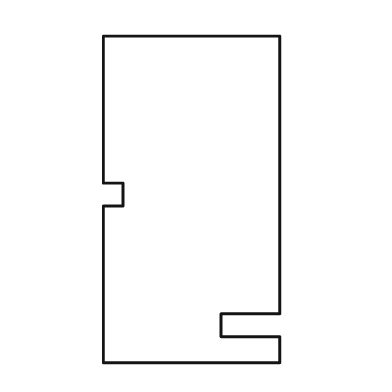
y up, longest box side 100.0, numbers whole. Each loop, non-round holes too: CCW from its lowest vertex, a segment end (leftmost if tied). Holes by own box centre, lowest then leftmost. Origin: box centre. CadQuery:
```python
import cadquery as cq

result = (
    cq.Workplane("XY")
    .moveTo(-27.0, -50.0)
    .lineTo(27.0, -50.0)
    .lineTo(27.0, -42.0)
    .lineTo(9.0, -42.0)
    .lineTo(9.0, -35.0)
    .lineTo(27.0, -35.0)
    .lineTo(27.0, 50.0)
    .lineTo(-27.0, 50.0)
    .lineTo(-27.0, 5.0)
    .lineTo(-21.0, 5.0)
    .lineTo(-21.0, -2.0)
    .lineTo(-27.0, -2.0)
    .close()
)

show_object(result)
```